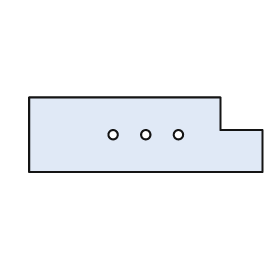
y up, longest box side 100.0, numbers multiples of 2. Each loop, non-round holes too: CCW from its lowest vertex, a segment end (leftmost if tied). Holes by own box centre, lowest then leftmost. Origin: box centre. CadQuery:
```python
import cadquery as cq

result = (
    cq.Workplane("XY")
    .moveTo(-50.0, -16.0)
    .lineTo(50.0, -16.0)
    .lineTo(50.0, 2.0)
    .lineTo(32.0, 2.0)
    .lineTo(32.0, 16.0)
    .lineTo(-50.0, 16.0)
    .close()
    .moveTo(-14.0, 0.0)
    .circle(2.0)
    .moveTo(0.0, 0.0)
    .circle(2.0)
    .moveTo(14.0, 0.0)
    .circle(2.0)
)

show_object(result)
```